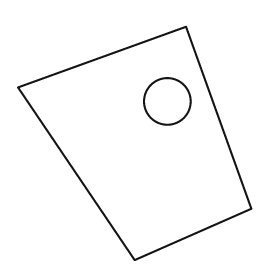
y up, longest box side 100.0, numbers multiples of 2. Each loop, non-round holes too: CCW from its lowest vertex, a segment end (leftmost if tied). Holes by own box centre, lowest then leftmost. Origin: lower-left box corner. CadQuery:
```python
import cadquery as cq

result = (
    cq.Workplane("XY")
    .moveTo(50.0, 0.0)
    .lineTo(100.0, 22.0)
    .lineTo(72.0, 100.0)
    .lineTo(0.0, 74.0)
    .close()
    .moveTo(64.0, 68.0)
    .circle(10.0)
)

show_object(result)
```